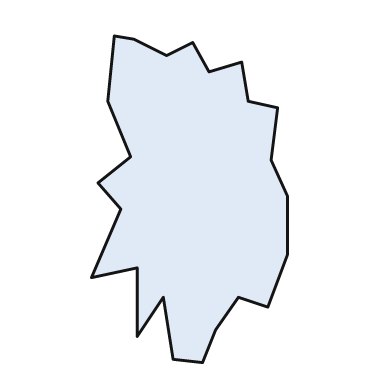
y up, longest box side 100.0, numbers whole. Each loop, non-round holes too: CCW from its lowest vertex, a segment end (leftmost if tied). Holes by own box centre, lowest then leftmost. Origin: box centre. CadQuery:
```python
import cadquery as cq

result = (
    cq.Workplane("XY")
    .moveTo(4.0, -50.0)
    .lineTo(8.0, -40.0)
    .lineTo(15.0, -30.0)
    .lineTo(24.0, -33.0)
    .lineTo(30.0, -17.0)
    .lineTo(30.0, 1.0)
    .lineTo(25.0, 12.0)
    .lineTo(27.0, 28.0)
    .lineTo(18.0, 30.0)
    .lineTo(16.0, 42.0)
    .lineTo(6.0, 39.0)
    .lineTo(1.0, 48.0)
    .lineTo(-7.0, 44.0)
    .lineTo(-17.0, 49.0)
    .lineTo(-23.0, 50.0)
    .lineTo(-25.0, 30.0)
    .lineTo(-18.0, 13.0)
    .lineTo(-28.0, 5.0)
    .lineTo(-21.0, -3.0)
    .lineTo(-30.0, -24.0)
    .lineTo(-16.0, -21.0)
    .lineTo(-16.0, -42.0)
    .lineTo(-8.0, -30.0)
    .lineTo(-5.0, -49.0)
    .close()
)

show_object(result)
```